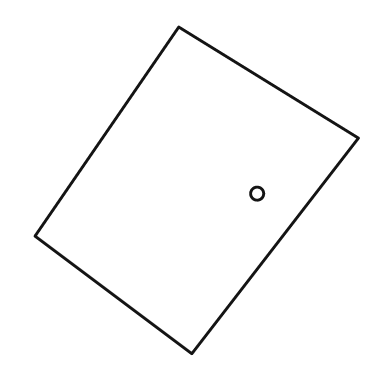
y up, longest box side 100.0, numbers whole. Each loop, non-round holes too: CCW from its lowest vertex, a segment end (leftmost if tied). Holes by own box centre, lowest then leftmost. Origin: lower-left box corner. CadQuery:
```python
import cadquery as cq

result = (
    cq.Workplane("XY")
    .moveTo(48.0, 0.0)
    .lineTo(99.0, 66.0)
    .lineTo(44.0, 100.0)
    .lineTo(0.0, 36.0)
    .close()
    .moveTo(68.0, 49.0)
    .circle(2.0)
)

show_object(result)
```